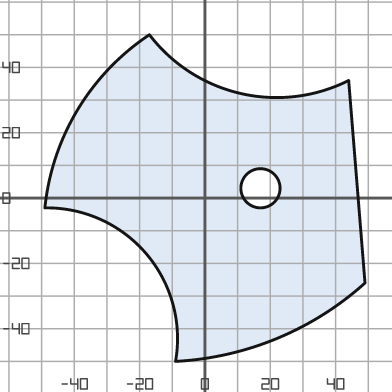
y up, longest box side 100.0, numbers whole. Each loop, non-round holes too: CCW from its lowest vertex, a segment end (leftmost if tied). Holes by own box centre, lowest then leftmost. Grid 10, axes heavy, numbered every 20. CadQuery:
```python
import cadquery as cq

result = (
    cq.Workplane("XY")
    .moveTo(-9.0, -50.0)
    .threePointArc((22.0, -43.0), (49.0, -26.0))
    .lineTo(44.0, 36.0)
    .threePointArc((11.0, 32.0), (-17.0, 50.0))
    .threePointArc((-39.0, 27.0), (-49.0, -3.0))
    .threePointArc((-18.0, -17.0), (-9.0, -50.0))
    .close()
    .moveTo(17.0, 3.0)
    .circle(6.0)
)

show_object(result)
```